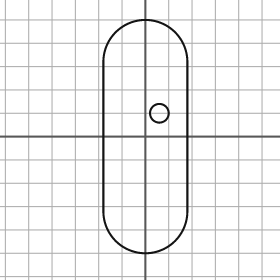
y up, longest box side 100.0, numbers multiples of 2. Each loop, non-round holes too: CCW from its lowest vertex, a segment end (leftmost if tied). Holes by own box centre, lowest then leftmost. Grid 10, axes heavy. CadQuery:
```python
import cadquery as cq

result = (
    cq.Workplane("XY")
    .moveTo(-18.0, -32.0)
    .threePointArc((0.0, -50.0), (18.0, -32.0))
    .lineTo(18.0, 32.0)
    .threePointArc((0.0, 50.0), (-18.0, 32.0))
    .close()
    .moveTo(6.0, 10.0)
    .circle(4.0)
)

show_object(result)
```